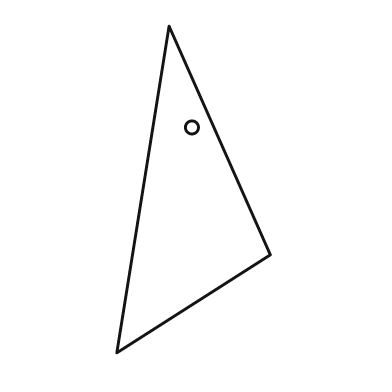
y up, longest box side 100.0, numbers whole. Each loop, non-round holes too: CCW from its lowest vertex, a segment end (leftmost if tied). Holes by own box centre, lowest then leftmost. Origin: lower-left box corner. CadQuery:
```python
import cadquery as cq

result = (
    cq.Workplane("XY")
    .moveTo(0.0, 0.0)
    .lineTo(47.0, 30.0)
    .lineTo(16.0, 100.0)
    .close()
    .moveTo(23.0, 69.0)
    .circle(2.0)
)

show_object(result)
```